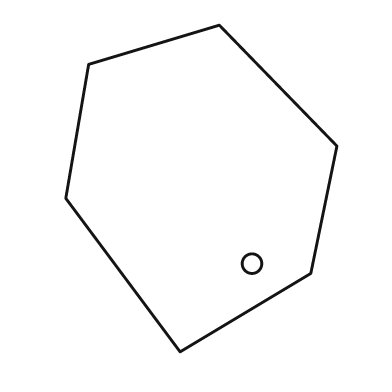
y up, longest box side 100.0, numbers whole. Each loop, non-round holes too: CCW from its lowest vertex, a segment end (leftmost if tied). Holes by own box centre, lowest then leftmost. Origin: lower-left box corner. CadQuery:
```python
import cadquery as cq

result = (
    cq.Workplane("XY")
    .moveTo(35.0, 0.0)
    .lineTo(75.0, 24.0)
    .lineTo(83.0, 63.0)
    .lineTo(47.0, 100.0)
    .lineTo(7.0, 88.0)
    .lineTo(0.0, 47.0)
    .close()
    .moveTo(57.0, 27.0)
    .circle(3.0)
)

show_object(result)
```